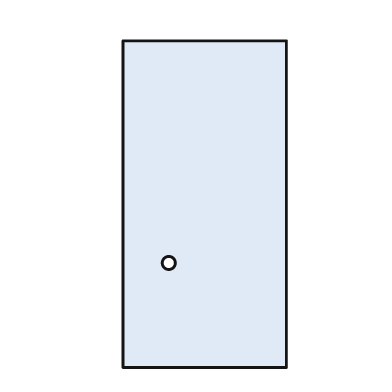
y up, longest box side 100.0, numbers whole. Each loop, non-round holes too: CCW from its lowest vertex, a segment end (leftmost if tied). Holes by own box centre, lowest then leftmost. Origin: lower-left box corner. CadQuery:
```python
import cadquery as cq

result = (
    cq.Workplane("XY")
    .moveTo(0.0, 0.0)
    .lineTo(50.0, 0.0)
    .lineTo(50.0, 100.0)
    .lineTo(0.0, 100.0)
    .close()
    .moveTo(14.0, 32.0)
    .circle(2.0)
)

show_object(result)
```